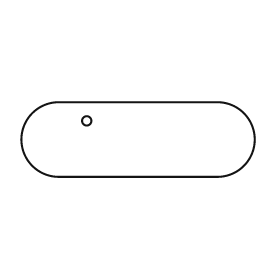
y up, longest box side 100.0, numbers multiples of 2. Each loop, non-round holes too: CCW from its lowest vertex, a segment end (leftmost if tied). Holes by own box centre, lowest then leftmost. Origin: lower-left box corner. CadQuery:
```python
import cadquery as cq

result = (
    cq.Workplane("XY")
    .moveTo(16.0, 0.0)
    .lineTo(84.0, 0.0)
    .threePointArc((100.0, 16.0), (84.0, 32.0))
    .lineTo(16.0, 32.0)
    .threePointArc((0.0, 16.0), (16.0, 0.0))
    .close()
    .moveTo(28.0, 24.0)
    .circle(2.0)
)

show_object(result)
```